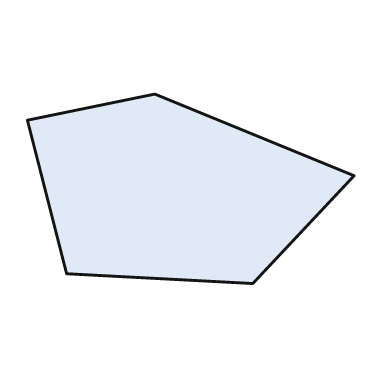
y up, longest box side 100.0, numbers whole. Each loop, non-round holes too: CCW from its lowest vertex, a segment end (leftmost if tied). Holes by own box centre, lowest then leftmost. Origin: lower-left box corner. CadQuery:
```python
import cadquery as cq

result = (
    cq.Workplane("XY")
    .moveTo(69.0, 0.0)
    .lineTo(100.0, 33.0)
    .lineTo(39.0, 58.0)
    .lineTo(0.0, 50.0)
    .lineTo(12.0, 3.0)
    .close()
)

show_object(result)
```